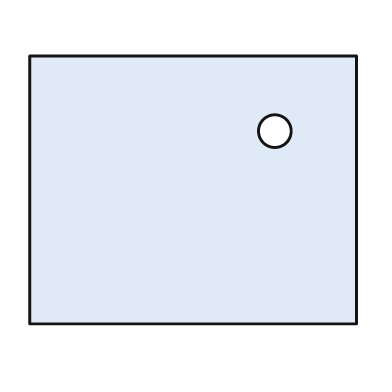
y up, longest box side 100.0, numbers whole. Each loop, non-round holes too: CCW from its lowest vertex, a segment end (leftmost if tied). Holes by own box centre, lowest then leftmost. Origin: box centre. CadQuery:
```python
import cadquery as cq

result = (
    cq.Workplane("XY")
    .moveTo(-50.0, -41.0)
    .lineTo(50.0, -41.0)
    .lineTo(50.0, 41.0)
    .lineTo(-50.0, 41.0)
    .close()
    .moveTo(25.0, 18.0)
    .circle(5.0)
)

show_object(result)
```